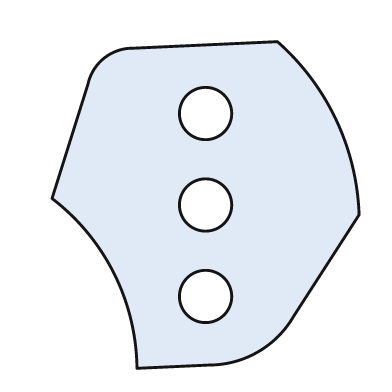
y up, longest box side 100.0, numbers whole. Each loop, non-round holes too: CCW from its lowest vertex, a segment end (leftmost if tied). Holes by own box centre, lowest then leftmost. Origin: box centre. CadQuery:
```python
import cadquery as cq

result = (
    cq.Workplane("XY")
    .moveTo(-21.0, -50.0)
    .lineTo(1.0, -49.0)
    .threePointArc((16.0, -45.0), (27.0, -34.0))
    .lineTo(47.0, -3.0)
    .threePointArc((40.0, 26.0), (22.0, 50.0))
    .lineTo(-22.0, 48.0)
    .threePointArc((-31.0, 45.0), (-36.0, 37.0))
    .lineTo(-47.0, 2.0)
    .threePointArc((-28.0, -21.0), (-21.0, -50.0))
    .close()
    .moveTo(0.0, -28.0)
    .circle(8.0)
    .moveTo(0.0, 0.0)
    .circle(8.0)
    .moveTo(0.0, 28.0)
    .circle(8.0)
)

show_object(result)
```